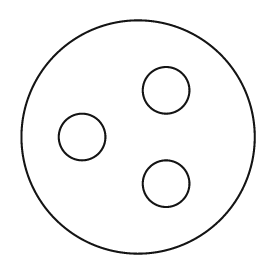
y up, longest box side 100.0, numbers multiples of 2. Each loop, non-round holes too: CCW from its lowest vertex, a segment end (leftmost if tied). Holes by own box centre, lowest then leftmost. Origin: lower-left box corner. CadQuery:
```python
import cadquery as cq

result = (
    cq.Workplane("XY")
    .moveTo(50.0, 50.0)
    .circle(50.0)
    .moveTo(62.0, 30.0)
    .circle(10.0)
    .moveTo(26.0, 50.0)
    .circle(10.0)
    .moveTo(62.0, 70.0)
    .circle(10.0)
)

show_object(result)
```